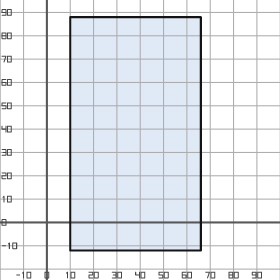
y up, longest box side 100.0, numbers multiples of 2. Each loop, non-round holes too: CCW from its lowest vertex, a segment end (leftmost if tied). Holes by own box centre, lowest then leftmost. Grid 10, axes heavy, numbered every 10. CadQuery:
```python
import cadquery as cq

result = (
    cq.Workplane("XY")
    .moveTo(10.0, -12.0)
    .lineTo(66.0, -12.0)
    .lineTo(66.0, 88.0)
    .lineTo(10.0, 88.0)
    .close()
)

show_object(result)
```